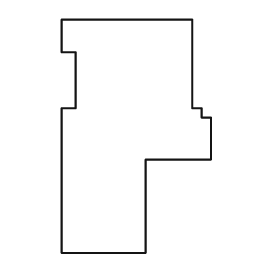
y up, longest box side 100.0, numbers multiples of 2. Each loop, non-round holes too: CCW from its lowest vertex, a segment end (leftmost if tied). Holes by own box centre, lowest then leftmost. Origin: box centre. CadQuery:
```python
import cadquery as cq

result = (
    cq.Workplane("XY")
    .moveTo(-32.0, -50.0)
    .lineTo(4.0, -50.0)
    .lineTo(4.0, -10.0)
    .lineTo(32.0, -10.0)
    .lineTo(32.0, 8.0)
    .lineTo(28.0, 8.0)
    .lineTo(28.0, 12.0)
    .lineTo(24.0, 12.0)
    .lineTo(24.0, 50.0)
    .lineTo(-32.0, 50.0)
    .lineTo(-32.0, 36.0)
    .lineTo(-26.0, 36.0)
    .lineTo(-26.0, 12.0)
    .lineTo(-32.0, 12.0)
    .close()
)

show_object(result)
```